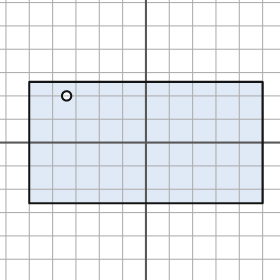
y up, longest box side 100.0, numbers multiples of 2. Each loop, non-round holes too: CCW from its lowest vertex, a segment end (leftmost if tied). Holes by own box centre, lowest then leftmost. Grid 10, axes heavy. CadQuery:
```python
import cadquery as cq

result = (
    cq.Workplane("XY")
    .moveTo(-50.0, -26.0)
    .lineTo(50.0, -26.0)
    .lineTo(50.0, 26.0)
    .lineTo(-50.0, 26.0)
    .close()
    .moveTo(-34.0, 20.0)
    .circle(2.0)
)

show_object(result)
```